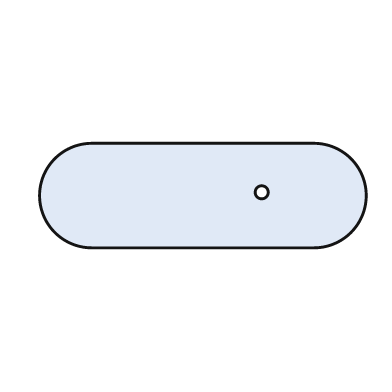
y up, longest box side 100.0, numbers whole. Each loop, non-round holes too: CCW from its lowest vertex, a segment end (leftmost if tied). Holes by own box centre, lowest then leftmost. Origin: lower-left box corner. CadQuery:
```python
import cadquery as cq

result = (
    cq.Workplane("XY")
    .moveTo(16.0, 0.0)
    .lineTo(84.0, 0.0)
    .threePointArc((100.0, 16.0), (84.0, 32.0))
    .lineTo(16.0, 32.0)
    .threePointArc((0.0, 16.0), (16.0, 0.0))
    .close()
    .moveTo(68.0, 17.0)
    .circle(2.0)
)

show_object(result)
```